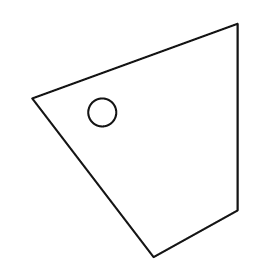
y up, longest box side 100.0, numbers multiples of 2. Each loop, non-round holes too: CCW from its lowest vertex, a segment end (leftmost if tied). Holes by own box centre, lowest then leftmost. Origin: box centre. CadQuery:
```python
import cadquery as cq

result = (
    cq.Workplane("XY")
    .moveTo(8.0, -50.0)
    .lineTo(44.0, -30.0)
    .lineTo(44.0, 50.0)
    .lineTo(-44.0, 18.0)
    .close()
    .moveTo(-14.0, 12.0)
    .circle(6.0)
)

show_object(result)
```